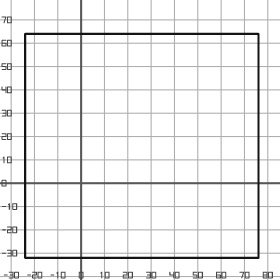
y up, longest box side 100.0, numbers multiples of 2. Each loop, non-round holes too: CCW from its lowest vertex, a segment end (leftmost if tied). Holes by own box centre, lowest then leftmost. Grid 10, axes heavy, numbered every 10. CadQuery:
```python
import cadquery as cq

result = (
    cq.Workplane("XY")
    .moveTo(-24.0, -32.0)
    .lineTo(76.0, -32.0)
    .lineTo(76.0, 64.0)
    .lineTo(-24.0, 64.0)
    .close()
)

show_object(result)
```